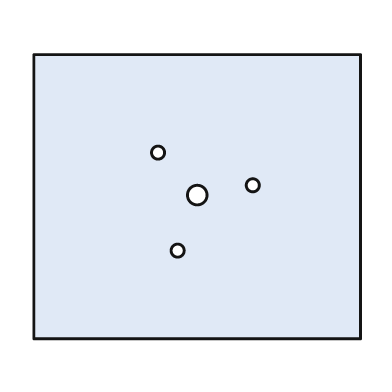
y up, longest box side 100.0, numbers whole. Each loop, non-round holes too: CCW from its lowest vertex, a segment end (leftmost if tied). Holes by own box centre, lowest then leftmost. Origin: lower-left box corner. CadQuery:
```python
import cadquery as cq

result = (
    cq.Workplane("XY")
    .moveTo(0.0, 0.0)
    .lineTo(100.0, 0.0)
    .lineTo(100.0, 87.0)
    .lineTo(0.0, 87.0)
    .close()
    .moveTo(44.0, 27.0)
    .circle(2.0)
    .moveTo(50.0, 44.0)
    .circle(3.0)
    .moveTo(67.0, 47.0)
    .circle(2.0)
    .moveTo(38.0, 57.0)
    .circle(2.0)
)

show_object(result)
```